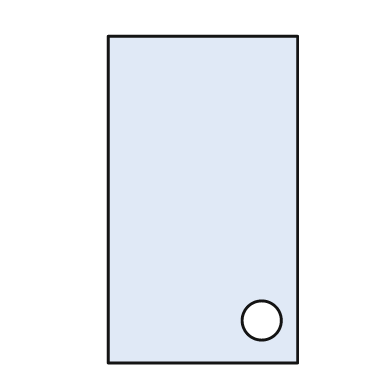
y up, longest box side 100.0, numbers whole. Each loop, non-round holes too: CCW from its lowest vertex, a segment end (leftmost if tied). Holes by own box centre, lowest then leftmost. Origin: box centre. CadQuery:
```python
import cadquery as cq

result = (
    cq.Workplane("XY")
    .moveTo(-29.0, -50.0)
    .lineTo(29.0, -50.0)
    .lineTo(29.0, 50.0)
    .lineTo(-29.0, 50.0)
    .close()
    .moveTo(18.0, -37.0)
    .circle(6.0)
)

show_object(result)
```